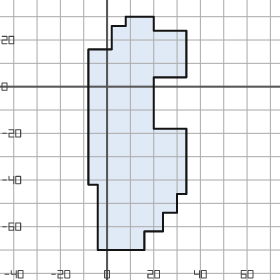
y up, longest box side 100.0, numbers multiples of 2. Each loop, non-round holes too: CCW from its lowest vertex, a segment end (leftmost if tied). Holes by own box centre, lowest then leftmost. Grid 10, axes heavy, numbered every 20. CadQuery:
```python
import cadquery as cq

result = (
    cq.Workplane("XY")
    .moveTo(-4.0, -70.0)
    .lineTo(16.0, -70.0)
    .lineTo(16.0, -62.0)
    .lineTo(24.0, -62.0)
    .lineTo(24.0, -54.0)
    .lineTo(30.0, -54.0)
    .lineTo(30.0, -46.0)
    .lineTo(34.0, -46.0)
    .lineTo(34.0, -18.0)
    .lineTo(20.0, -18.0)
    .lineTo(20.0, 4.0)
    .lineTo(34.0, 4.0)
    .lineTo(34.0, 24.0)
    .lineTo(20.0, 24.0)
    .lineTo(20.0, 30.0)
    .lineTo(8.0, 30.0)
    .lineTo(8.0, 26.0)
    .lineTo(2.0, 26.0)
    .lineTo(2.0, 16.0)
    .lineTo(-8.0, 16.0)
    .lineTo(-8.0, -42.0)
    .lineTo(-4.0, -42.0)
    .close()
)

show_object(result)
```